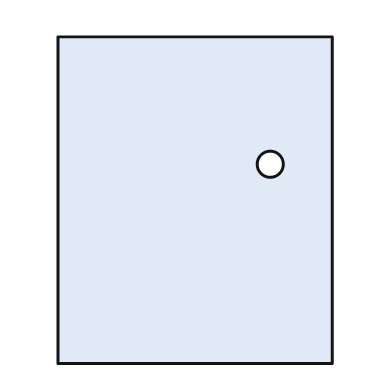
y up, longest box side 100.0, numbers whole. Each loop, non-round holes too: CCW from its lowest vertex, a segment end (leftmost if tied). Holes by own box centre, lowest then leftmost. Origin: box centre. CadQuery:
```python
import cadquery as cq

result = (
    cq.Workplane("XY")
    .moveTo(-42.0, -50.0)
    .lineTo(42.0, -50.0)
    .lineTo(42.0, 50.0)
    .lineTo(-42.0, 50.0)
    .close()
    .moveTo(23.0, 11.0)
    .circle(4.0)
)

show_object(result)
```